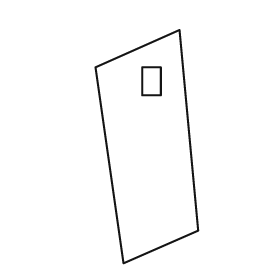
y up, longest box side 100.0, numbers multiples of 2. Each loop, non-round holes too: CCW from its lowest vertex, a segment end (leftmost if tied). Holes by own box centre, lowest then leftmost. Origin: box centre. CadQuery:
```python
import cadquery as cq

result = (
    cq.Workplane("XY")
    .moveTo(-10.0, -50.0)
    .lineTo(22.0, -36.0)
    .lineTo(14.0, 50.0)
    .lineTo(-22.0, 34.0)
    .close()
    .moveTo(-2.0, 22.0)
    .lineTo(6.0, 22.0)
    .lineTo(6.0, 34.0)
    .lineTo(-2.0, 34.0)
    .close()
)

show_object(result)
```